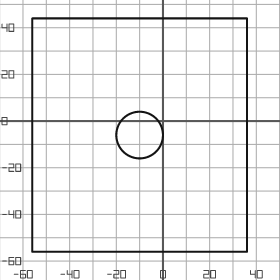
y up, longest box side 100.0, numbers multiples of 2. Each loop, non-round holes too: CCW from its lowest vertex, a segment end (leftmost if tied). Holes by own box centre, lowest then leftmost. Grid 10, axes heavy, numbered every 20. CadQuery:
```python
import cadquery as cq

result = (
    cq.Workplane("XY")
    .moveTo(-56.0, -56.0)
    .lineTo(36.0, -56.0)
    .lineTo(36.0, 44.0)
    .lineTo(-56.0, 44.0)
    .close()
    .moveTo(-10.0, -6.0)
    .circle(10.0)
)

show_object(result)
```